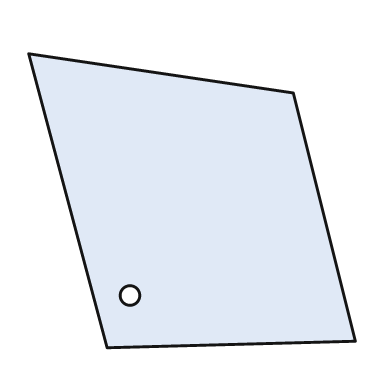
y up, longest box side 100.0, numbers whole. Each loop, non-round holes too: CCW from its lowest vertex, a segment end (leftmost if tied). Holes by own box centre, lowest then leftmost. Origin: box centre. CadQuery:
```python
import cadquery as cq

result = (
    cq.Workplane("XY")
    .moveTo(-26.0, -45.0)
    .lineTo(50.0, -43.0)
    .lineTo(31.0, 33.0)
    .lineTo(-50.0, 45.0)
    .close()
    .moveTo(-19.0, -29.0)
    .circle(3.0)
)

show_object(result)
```